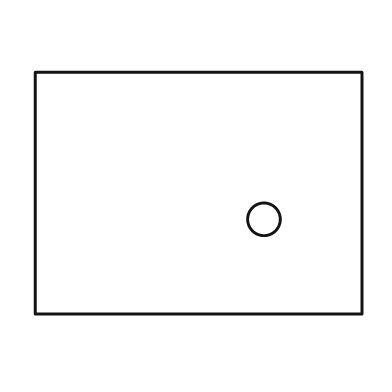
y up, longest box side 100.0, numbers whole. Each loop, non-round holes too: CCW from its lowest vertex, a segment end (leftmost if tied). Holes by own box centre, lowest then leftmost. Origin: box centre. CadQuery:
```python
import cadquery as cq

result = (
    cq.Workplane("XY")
    .moveTo(-50.0, -37.0)
    .lineTo(50.0, -37.0)
    .lineTo(50.0, 37.0)
    .lineTo(-50.0, 37.0)
    .close()
    .moveTo(20.0, -8.0)
    .circle(5.0)
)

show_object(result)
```